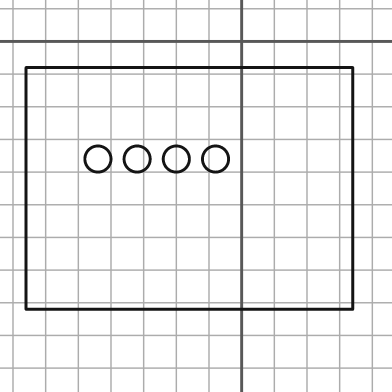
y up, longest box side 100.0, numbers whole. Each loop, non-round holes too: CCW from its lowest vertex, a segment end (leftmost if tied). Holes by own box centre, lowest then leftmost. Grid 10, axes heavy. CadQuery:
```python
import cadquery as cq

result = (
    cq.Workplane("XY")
    .moveTo(-66.0, -82.0)
    .lineTo(34.0, -82.0)
    .lineTo(34.0, -8.0)
    .lineTo(-66.0, -8.0)
    .close()
    .moveTo(-44.0, -36.0)
    .circle(4.0)
    .moveTo(-32.0, -36.0)
    .circle(4.0)
    .moveTo(-20.0, -36.0)
    .circle(4.0)
    .moveTo(-8.0, -36.0)
    .circle(4.0)
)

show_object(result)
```